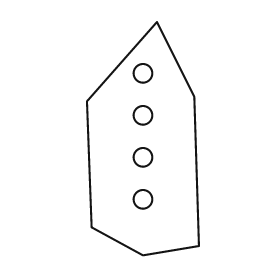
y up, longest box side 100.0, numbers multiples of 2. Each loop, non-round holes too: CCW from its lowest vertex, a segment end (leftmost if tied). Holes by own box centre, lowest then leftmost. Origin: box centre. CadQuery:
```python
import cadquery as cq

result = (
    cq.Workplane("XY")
    .moveTo(0.0, -50.0)
    .lineTo(24.0, -46.0)
    .lineTo(22.0, 18.0)
    .lineTo(6.0, 50.0)
    .lineTo(-24.0, 16.0)
    .lineTo(-22.0, -38.0)
    .close()
    .moveTo(0.0, -26.0)
    .circle(4.0)
    .moveTo(0.0, -8.0)
    .circle(4.0)
    .moveTo(0.0, 10.0)
    .circle(4.0)
    .moveTo(0.0, 28.0)
    .circle(4.0)
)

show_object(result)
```